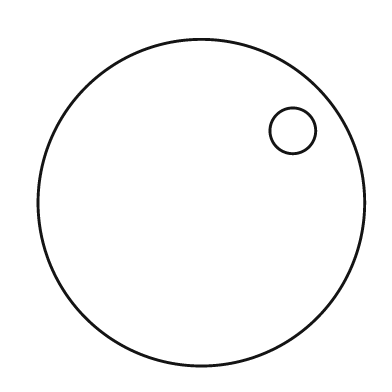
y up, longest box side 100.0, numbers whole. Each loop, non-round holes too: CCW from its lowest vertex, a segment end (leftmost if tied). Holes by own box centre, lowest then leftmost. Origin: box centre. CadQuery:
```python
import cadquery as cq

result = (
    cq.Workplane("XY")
    .moveTo(0.0, 0.0)
    .circle(50.0)
    .moveTo(28.0, 22.0)
    .circle(7.0)
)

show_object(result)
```